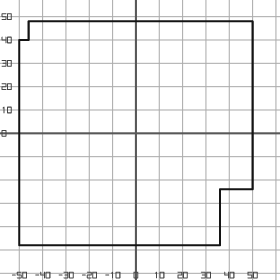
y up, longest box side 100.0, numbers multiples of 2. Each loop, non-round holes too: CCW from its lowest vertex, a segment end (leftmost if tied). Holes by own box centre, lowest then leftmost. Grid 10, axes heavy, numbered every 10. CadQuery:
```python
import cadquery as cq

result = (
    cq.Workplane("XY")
    .moveTo(-50.0, -48.0)
    .lineTo(36.0, -48.0)
    .lineTo(36.0, -24.0)
    .lineTo(50.0, -24.0)
    .lineTo(50.0, 48.0)
    .lineTo(-46.0, 48.0)
    .lineTo(-46.0, 40.0)
    .lineTo(-50.0, 40.0)
    .close()
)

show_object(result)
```